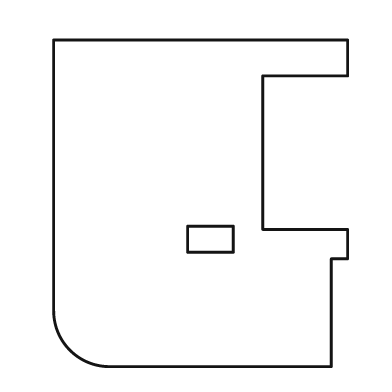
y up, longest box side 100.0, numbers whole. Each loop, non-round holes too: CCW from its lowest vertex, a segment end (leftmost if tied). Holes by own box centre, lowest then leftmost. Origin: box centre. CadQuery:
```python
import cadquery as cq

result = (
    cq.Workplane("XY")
    .moveTo(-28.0, -50.0)
    .lineTo(40.0, -50.0)
    .lineTo(40.0, -17.0)
    .lineTo(45.0, -17.0)
    .lineTo(45.0, -8.0)
    .lineTo(19.0, -8.0)
    .lineTo(19.0, 39.0)
    .lineTo(45.0, 39.0)
    .lineTo(45.0, 50.0)
    .lineTo(-45.0, 50.0)
    .lineTo(-45.0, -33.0)
    .threePointArc((-40.0, -45.0), (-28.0, -50.0))
    .close()
    .moveTo(-4.0, -15.0)
    .lineTo(10.0, -15.0)
    .lineTo(10.0, -7.0)
    .lineTo(-4.0, -7.0)
    .close()
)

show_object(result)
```